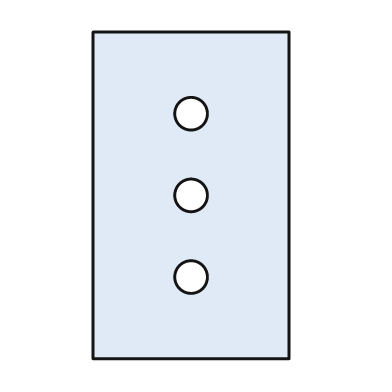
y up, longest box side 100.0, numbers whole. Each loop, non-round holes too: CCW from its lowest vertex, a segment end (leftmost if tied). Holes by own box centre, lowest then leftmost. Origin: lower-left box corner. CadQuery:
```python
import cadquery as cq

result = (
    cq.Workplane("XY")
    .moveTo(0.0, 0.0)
    .lineTo(60.0, 0.0)
    .lineTo(60.0, 100.0)
    .lineTo(0.0, 100.0)
    .close()
    .moveTo(30.0, 25.0)
    .circle(5.0)
    .moveTo(30.0, 50.0)
    .circle(5.0)
    .moveTo(30.0, 75.0)
    .circle(5.0)
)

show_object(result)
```